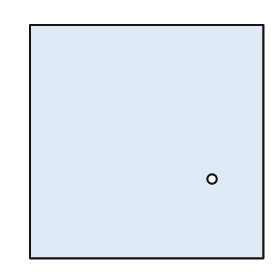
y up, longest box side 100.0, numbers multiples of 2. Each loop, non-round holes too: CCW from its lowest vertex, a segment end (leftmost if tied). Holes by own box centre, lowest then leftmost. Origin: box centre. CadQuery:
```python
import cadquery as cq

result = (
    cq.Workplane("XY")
    .moveTo(-50.0, -50.0)
    .lineTo(50.0, -50.0)
    .lineTo(50.0, 50.0)
    .lineTo(-50.0, 50.0)
    .close()
    .moveTo(28.0, -16.0)
    .circle(2.0)
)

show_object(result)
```